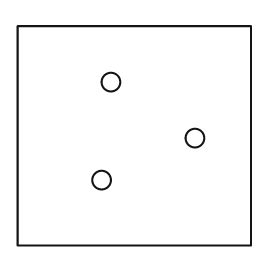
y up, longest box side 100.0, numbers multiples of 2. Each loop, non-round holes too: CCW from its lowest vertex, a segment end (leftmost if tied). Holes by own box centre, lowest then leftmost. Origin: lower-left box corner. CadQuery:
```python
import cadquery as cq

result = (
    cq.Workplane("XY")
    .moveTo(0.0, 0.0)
    .lineTo(100.0, 0.0)
    .lineTo(100.0, 94.0)
    .lineTo(0.0, 94.0)
    .close()
    .moveTo(36.0, 28.0)
    .circle(4.0)
    .moveTo(76.0, 46.0)
    .circle(4.0)
    .moveTo(40.0, 70.0)
    .circle(4.0)
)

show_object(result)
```